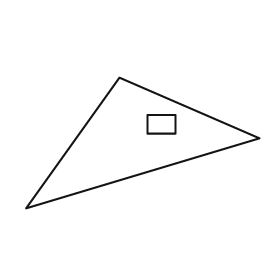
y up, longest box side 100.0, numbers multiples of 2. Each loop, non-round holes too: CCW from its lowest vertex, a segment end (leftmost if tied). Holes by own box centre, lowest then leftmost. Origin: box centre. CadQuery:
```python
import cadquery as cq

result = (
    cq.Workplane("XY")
    .moveTo(-50.0, -28.0)
    .lineTo(50.0, 2.0)
    .lineTo(-10.0, 28.0)
    .close()
    .moveTo(2.0, 4.0)
    .lineTo(14.0, 4.0)
    .lineTo(14.0, 12.0)
    .lineTo(2.0, 12.0)
    .close()
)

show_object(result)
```